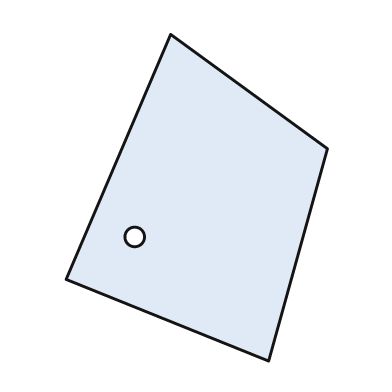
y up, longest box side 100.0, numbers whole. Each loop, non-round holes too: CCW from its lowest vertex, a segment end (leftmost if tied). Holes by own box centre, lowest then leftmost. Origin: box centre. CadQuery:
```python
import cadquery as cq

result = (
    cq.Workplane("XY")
    .moveTo(22.0, -50.0)
    .lineTo(40.0, 15.0)
    .lineTo(-8.0, 50.0)
    .lineTo(-40.0, -25.0)
    .close()
    .moveTo(-19.0, -12.0)
    .circle(3.0)
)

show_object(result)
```